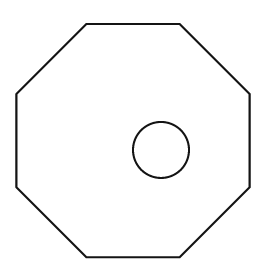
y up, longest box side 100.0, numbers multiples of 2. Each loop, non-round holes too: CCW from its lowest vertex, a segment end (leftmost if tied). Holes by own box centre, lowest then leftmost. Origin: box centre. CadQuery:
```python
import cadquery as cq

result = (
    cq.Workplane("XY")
    .moveTo(-20.0, -50.0)
    .lineTo(20.0, -50.0)
    .lineTo(50.0, -20.0)
    .lineTo(50.0, 20.0)
    .lineTo(20.0, 50.0)
    .lineTo(-20.0, 50.0)
    .lineTo(-50.0, 20.0)
    .lineTo(-50.0, -20.0)
    .close()
    .moveTo(12.0, -4.0)
    .circle(12.0)
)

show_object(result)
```